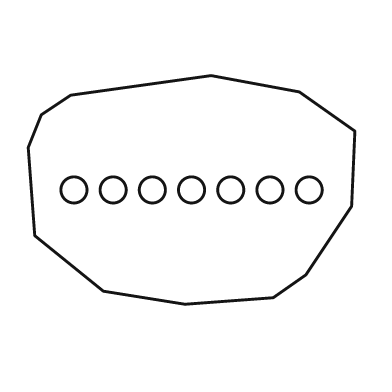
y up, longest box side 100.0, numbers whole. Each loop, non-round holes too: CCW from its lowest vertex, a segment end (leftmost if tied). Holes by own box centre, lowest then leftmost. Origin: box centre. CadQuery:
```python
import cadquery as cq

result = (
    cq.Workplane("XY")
    .moveTo(-2.0, -35.0)
    .lineTo(25.0, -33.0)
    .lineTo(35.0, -26.0)
    .lineTo(49.0, -5.0)
    .lineTo(50.0, 18.0)
    .lineTo(33.0, 30.0)
    .lineTo(6.0, 35.0)
    .lineTo(-37.0, 29.0)
    .lineTo(-46.0, 23.0)
    .lineTo(-50.0, 13.0)
    .lineTo(-48.0, -14.0)
    .lineTo(-27.0, -31.0)
    .close()
    .moveTo(-36.0, 0.0)
    .circle(4.0)
    .moveTo(-24.0, 0.0)
    .circle(4.0)
    .moveTo(-12.0, 0.0)
    .circle(4.0)
    .moveTo(0.0, 0.0)
    .circle(4.0)
    .moveTo(12.0, 0.0)
    .circle(4.0)
    .moveTo(24.0, 0.0)
    .circle(4.0)
    .moveTo(36.0, 0.0)
    .circle(4.0)
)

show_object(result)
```